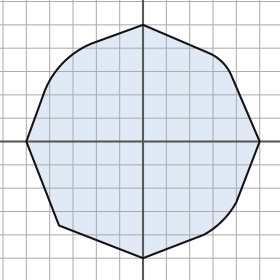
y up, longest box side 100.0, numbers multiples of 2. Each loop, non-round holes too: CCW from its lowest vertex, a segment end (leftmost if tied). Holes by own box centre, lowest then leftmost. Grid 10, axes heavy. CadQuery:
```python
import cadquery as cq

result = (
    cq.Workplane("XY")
    .moveTo(0.0, -50.0)
    .lineTo(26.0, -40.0)
    .threePointArc((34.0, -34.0), (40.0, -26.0))
    .lineTo(50.0, 0.0)
    .lineTo(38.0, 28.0)
    .threePointArc((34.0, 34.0), (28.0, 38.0))
    .lineTo(0.0, 50.0)
    .lineTo(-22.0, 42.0)
    .threePointArc((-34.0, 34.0), (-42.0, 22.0))
    .lineTo(-50.0, 0.0)
    .lineTo(-36.0, -36.0)
    .close()
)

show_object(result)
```